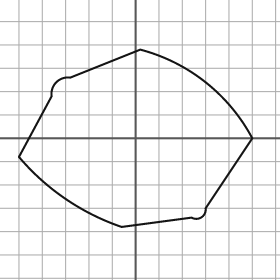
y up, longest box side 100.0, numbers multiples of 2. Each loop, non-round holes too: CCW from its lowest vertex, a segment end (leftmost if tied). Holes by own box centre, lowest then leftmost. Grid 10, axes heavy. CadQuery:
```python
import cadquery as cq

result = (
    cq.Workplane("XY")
    .moveTo(-6.0, -38.0)
    .lineTo(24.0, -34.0)
    .threePointArc((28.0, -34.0), (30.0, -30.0))
    .lineTo(50.0, 0.0)
    .threePointArc((30.0, 24.0), (2.0, 38.0))
    .lineTo(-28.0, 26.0)
    .threePointArc((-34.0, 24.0), (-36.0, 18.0))
    .lineTo(-50.0, -8.0)
    .threePointArc((-30.0, -26.0), (-6.0, -38.0))
    .close()
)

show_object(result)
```